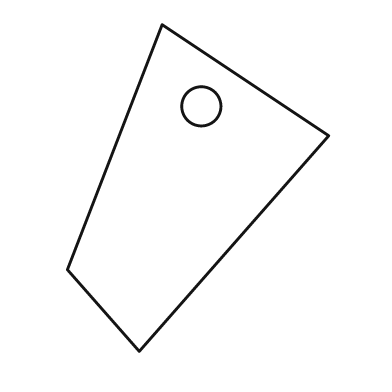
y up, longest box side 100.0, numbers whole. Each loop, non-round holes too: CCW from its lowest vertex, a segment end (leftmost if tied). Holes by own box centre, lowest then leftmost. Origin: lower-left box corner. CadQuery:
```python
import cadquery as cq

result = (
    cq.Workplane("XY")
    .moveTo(22.0, 0.0)
    .lineTo(80.0, 66.0)
    .lineTo(29.0, 100.0)
    .lineTo(0.0, 25.0)
    .close()
    .moveTo(41.0, 75.0)
    .circle(6.0)
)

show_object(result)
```